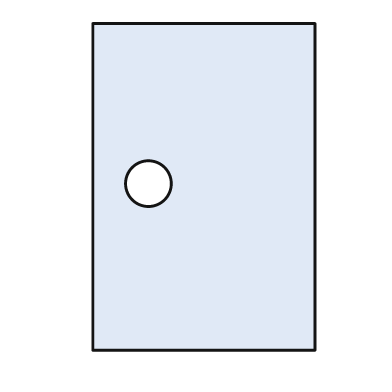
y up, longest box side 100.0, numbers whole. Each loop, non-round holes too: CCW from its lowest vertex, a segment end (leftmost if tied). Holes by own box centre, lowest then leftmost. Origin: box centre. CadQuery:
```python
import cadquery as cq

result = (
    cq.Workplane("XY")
    .moveTo(-34.0, -50.0)
    .lineTo(34.0, -50.0)
    .lineTo(34.0, 50.0)
    .lineTo(-34.0, 50.0)
    .close()
    .moveTo(-17.0, 1.0)
    .circle(7.0)
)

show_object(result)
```